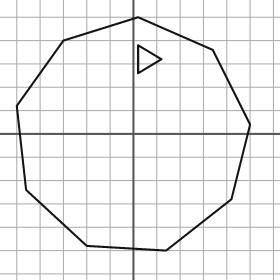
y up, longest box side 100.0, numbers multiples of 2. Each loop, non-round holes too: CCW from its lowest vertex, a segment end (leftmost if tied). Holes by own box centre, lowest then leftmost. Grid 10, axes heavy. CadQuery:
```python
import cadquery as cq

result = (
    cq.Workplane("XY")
    .moveTo(14.0, -50.0)
    .lineTo(42.0, -28.0)
    .lineTo(50.0, 4.0)
    .lineTo(34.0, 36.0)
    .lineTo(2.0, 50.0)
    .lineTo(-30.0, 40.0)
    .lineTo(-50.0, 12.0)
    .lineTo(-46.0, -24.0)
    .lineTo(-20.0, -48.0)
    .close()
    .moveTo(2.0, 26.0)
    .lineTo(12.0, 32.0)
    .lineTo(2.0, 38.0)
    .close()
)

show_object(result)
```